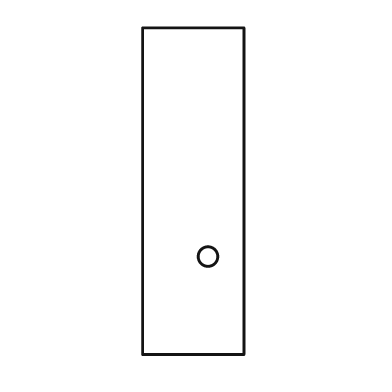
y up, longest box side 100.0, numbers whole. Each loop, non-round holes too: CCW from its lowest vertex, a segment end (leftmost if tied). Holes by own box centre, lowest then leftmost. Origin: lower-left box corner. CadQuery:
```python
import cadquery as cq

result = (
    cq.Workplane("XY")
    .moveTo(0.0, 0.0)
    .lineTo(31.0, 0.0)
    .lineTo(31.0, 100.0)
    .lineTo(0.0, 100.0)
    .close()
    .moveTo(20.0, 30.0)
    .circle(3.0)
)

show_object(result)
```